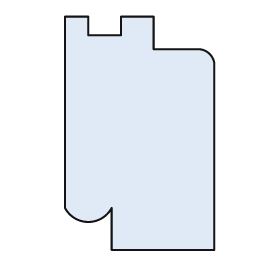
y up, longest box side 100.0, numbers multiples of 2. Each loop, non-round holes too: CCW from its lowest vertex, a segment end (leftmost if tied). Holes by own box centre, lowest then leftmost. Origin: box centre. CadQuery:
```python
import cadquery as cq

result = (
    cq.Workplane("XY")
    .moveTo(-12.0, -50.0)
    .lineTo(32.0, -50.0)
    .lineTo(32.0, 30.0)
    .threePointArc((30.0, 34.0), (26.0, 36.0))
    .lineTo(6.0, 36.0)
    .lineTo(6.0, 50.0)
    .lineTo(-8.0, 50.0)
    .lineTo(-8.0, 42.0)
    .lineTo(-22.0, 42.0)
    .lineTo(-22.0, 50.0)
    .lineTo(-32.0, 50.0)
    .lineTo(-32.0, -32.0)
    .threePointArc((-22.0, -38.0), (-12.0, -32.0))
    .close()
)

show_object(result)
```